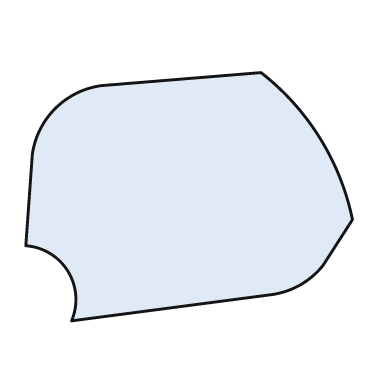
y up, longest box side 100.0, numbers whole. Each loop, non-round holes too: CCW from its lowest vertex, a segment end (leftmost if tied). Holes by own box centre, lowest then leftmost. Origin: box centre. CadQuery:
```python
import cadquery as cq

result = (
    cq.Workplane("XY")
    .moveTo(-36.0, -38.0)
    .lineTo(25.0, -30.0)
    .threePointArc((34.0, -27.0), (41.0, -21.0))
    .lineTo(50.0, -7.0)
    .threePointArc((40.0, 18.0), (22.0, 38.0))
    .lineTo(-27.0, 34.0)
    .threePointArc((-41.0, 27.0), (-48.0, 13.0))
    .lineTo(-50.0, -15.0)
    .threePointArc((-37.0, -23.0), (-36.0, -38.0))
    .close()
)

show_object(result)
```